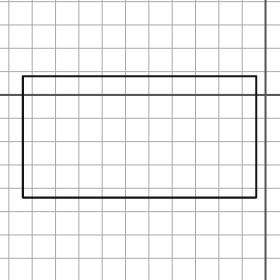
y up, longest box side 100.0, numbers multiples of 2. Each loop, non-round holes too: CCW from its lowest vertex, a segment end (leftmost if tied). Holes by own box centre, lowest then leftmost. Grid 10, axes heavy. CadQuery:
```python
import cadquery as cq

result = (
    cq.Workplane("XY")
    .moveTo(-104.0, -44.0)
    .lineTo(-4.0, -44.0)
    .lineTo(-4.0, 8.0)
    .lineTo(-104.0, 8.0)
    .close()
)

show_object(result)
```